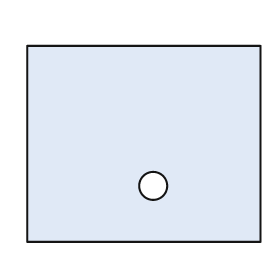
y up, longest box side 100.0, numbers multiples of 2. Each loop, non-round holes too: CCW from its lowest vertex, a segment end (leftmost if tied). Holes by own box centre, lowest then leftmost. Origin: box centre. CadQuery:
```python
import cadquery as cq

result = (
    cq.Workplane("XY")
    .moveTo(-50.0, -42.0)
    .lineTo(50.0, -42.0)
    .lineTo(50.0, 42.0)
    .lineTo(-50.0, 42.0)
    .close()
    .moveTo(4.0, -18.0)
    .circle(6.0)
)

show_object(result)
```